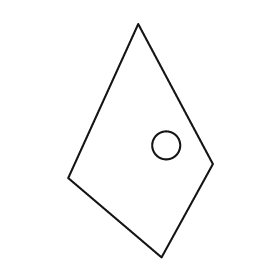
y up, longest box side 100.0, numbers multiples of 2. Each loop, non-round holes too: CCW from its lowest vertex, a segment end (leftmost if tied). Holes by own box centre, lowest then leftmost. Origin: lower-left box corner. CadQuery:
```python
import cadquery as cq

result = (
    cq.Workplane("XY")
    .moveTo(40.0, 0.0)
    .lineTo(62.0, 40.0)
    .lineTo(30.0, 100.0)
    .lineTo(0.0, 34.0)
    .close()
    .moveTo(42.0, 48.0)
    .circle(6.0)
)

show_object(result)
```